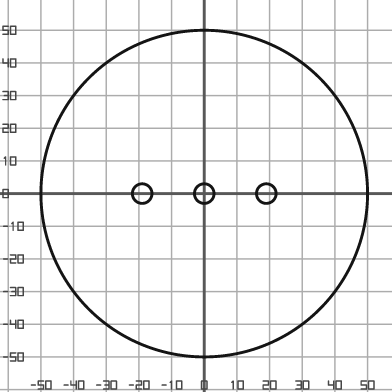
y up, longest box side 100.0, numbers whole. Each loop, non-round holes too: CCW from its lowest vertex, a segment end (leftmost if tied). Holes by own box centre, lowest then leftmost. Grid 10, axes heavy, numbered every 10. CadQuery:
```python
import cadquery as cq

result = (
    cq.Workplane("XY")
    .moveTo(0.0, 0.0)
    .circle(50.0)
    .moveTo(-19.0, 0.0)
    .circle(3.0)
    .moveTo(0.0, 0.0)
    .circle(3.0)
    .moveTo(19.0, 0.0)
    .circle(3.0)
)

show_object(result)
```